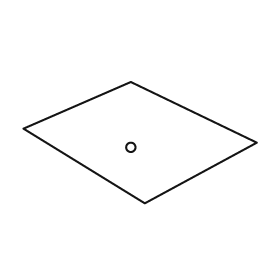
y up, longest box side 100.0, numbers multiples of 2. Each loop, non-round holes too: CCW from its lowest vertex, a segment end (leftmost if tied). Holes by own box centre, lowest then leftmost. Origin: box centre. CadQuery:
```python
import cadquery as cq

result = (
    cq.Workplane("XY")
    .moveTo(2.0, -26.0)
    .lineTo(50.0, 0.0)
    .lineTo(-4.0, 26.0)
    .lineTo(-50.0, 6.0)
    .close()
    .moveTo(-4.0, -2.0)
    .circle(2.0)
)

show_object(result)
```